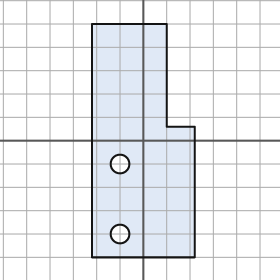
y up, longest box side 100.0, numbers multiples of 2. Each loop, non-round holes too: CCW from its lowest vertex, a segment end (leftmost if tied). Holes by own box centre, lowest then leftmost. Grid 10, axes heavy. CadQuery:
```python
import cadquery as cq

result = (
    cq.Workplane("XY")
    .moveTo(-22.0, -50.0)
    .lineTo(22.0, -50.0)
    .lineTo(22.0, 6.0)
    .lineTo(10.0, 6.0)
    .lineTo(10.0, 50.0)
    .lineTo(-22.0, 50.0)
    .close()
    .moveTo(-10.0, -40.0)
    .circle(4.0)
    .moveTo(-10.0, -10.0)
    .circle(4.0)
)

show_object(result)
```